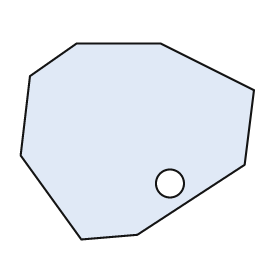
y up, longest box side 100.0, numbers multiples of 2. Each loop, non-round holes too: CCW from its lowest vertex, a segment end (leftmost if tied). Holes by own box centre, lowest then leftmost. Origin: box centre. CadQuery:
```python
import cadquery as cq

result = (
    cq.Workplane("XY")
    .moveTo(-24.0, -42.0)
    .lineTo(0.0, -40.0)
    .lineTo(46.0, -10.0)
    .lineTo(50.0, 22.0)
    .lineTo(10.0, 42.0)
    .lineTo(-26.0, 42.0)
    .lineTo(-46.0, 28.0)
    .lineTo(-50.0, -6.0)
    .close()
    .moveTo(14.0, -18.0)
    .circle(6.0)
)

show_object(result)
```